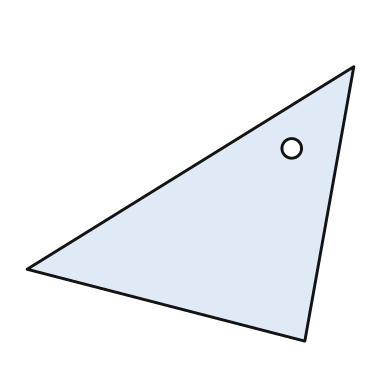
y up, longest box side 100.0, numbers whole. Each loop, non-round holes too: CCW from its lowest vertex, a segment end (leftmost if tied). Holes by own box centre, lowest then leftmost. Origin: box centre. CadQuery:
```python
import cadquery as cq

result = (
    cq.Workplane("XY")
    .moveTo(35.0, -42.0)
    .lineTo(50.0, 42.0)
    .lineTo(-50.0, -20.0)
    .close()
    .moveTo(31.0, 17.0)
    .circle(3.0)
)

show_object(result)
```